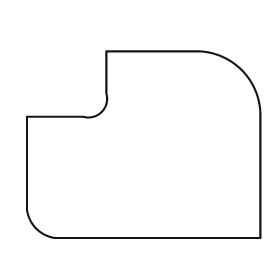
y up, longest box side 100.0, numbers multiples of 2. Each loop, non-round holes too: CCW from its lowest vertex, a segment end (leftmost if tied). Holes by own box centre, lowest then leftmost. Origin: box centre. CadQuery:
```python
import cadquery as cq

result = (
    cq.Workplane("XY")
    .moveTo(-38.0, -40.0)
    .lineTo(50.0, -40.0)
    .lineTo(50.0, 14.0)
    .threePointArc((42.0, 32.0), (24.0, 40.0))
    .lineTo(-16.0, 40.0)
    .lineTo(-16.0, 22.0)
    .threePointArc((-18.0, 14.0), (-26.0, 12.0))
    .lineTo(-50.0, 12.0)
    .lineTo(-50.0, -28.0)
    .threePointArc((-46.0, -36.0), (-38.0, -40.0))
    .close()
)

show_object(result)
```